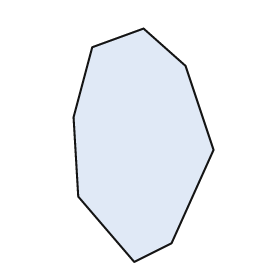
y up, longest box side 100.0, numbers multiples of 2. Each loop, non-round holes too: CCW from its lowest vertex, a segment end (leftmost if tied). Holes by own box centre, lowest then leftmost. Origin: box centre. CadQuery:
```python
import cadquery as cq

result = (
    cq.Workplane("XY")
    .moveTo(-4.0, -50.0)
    .lineTo(12.0, -42.0)
    .lineTo(30.0, -2.0)
    .lineTo(18.0, 34.0)
    .lineTo(0.0, 50.0)
    .lineTo(-22.0, 42.0)
    .lineTo(-30.0, 12.0)
    .lineTo(-28.0, -22.0)
    .close()
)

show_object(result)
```